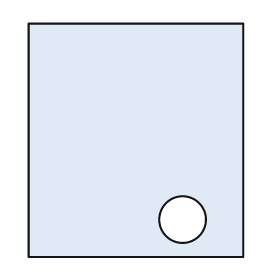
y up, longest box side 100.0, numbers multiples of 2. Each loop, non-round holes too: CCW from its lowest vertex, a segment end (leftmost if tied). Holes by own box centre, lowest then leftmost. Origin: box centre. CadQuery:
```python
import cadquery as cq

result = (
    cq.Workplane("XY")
    .moveTo(-46.0, -50.0)
    .lineTo(46.0, -50.0)
    .lineTo(46.0, 50.0)
    .lineTo(-46.0, 50.0)
    .close()
    .moveTo(20.0, -34.0)
    .circle(10.0)
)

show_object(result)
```